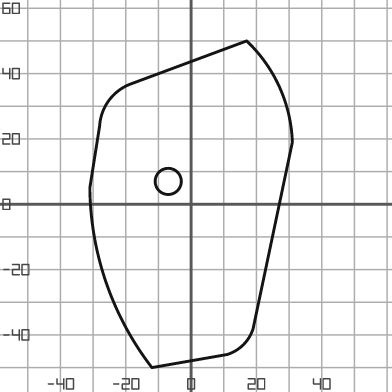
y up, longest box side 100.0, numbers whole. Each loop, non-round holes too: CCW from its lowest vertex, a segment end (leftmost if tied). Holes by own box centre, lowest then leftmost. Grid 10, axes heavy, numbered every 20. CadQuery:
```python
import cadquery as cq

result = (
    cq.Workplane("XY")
    .moveTo(-12.0, -50.0)
    .lineTo(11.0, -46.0)
    .threePointArc((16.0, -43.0), (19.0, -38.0))
    .lineTo(31.0, 19.0)
    .threePointArc((27.0, 36.0), (17.0, 50.0))
    .lineTo(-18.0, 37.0)
    .threePointArc((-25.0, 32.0), (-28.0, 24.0))
    .lineTo(-31.0, 5.0)
    .threePointArc((-26.0, -24.0), (-12.0, -50.0))
    .close()
    .moveTo(-7.0, 7.0)
    .circle(4.0)
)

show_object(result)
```